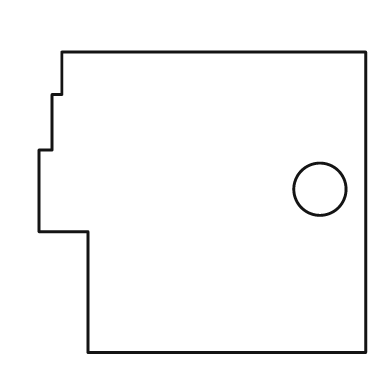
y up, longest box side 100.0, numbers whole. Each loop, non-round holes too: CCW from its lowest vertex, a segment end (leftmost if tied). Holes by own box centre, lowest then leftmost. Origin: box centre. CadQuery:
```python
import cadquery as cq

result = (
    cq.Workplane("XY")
    .moveTo(-35.0, -46.0)
    .lineTo(50.0, -46.0)
    .lineTo(50.0, 46.0)
    .lineTo(-43.0, 46.0)
    .lineTo(-43.0, 33.0)
    .lineTo(-46.0, 33.0)
    .lineTo(-46.0, 16.0)
    .lineTo(-50.0, 16.0)
    .lineTo(-50.0, -9.0)
    .lineTo(-35.0, -9.0)
    .close()
    .moveTo(36.0, 4.0)
    .circle(8.0)
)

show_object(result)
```